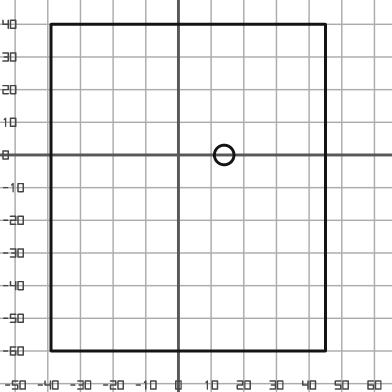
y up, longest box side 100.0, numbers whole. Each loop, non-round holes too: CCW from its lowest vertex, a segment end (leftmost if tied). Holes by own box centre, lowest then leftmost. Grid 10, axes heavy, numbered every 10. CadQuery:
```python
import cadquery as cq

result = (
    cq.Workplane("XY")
    .moveTo(-39.0, -60.0)
    .lineTo(45.0, -60.0)
    .lineTo(45.0, 40.0)
    .lineTo(-39.0, 40.0)
    .close()
    .moveTo(14.0, 0.0)
    .circle(3.0)
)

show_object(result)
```